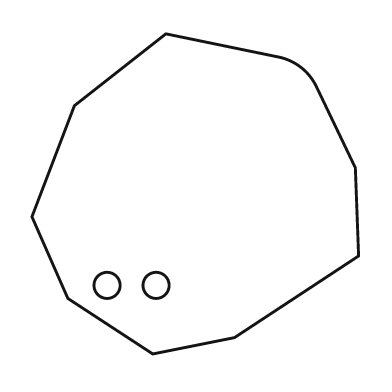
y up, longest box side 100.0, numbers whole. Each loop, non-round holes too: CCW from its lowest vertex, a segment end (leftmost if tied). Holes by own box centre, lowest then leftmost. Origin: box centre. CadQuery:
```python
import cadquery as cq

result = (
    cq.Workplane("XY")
    .moveTo(-13.0, -49.0)
    .lineTo(12.0, -44.0)
    .lineTo(50.0, -19.0)
    .lineTo(49.0, 8.0)
    .lineTo(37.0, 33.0)
    .threePointArc((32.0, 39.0), (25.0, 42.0))
    .lineTo(-9.0, 49.0)
    .lineTo(-37.0, 27.0)
    .lineTo(-50.0, -7.0)
    .lineTo(-39.0, -32.0)
    .close()
    .moveTo(-27.0, -28.0)
    .circle(4.0)
    .moveTo(-12.0, -28.0)
    .circle(4.0)
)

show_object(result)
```